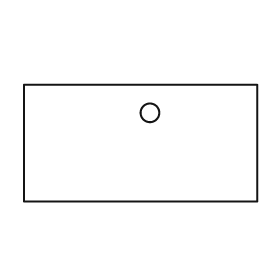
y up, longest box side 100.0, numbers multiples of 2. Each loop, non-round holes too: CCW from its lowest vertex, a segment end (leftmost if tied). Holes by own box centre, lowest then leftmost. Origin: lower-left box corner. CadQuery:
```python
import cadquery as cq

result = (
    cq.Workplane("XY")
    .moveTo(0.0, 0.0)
    .lineTo(100.0, 0.0)
    .lineTo(100.0, 50.0)
    .lineTo(0.0, 50.0)
    .close()
    .moveTo(54.0, 38.0)
    .circle(4.0)
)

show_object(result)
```